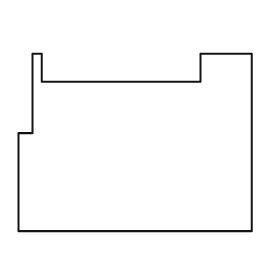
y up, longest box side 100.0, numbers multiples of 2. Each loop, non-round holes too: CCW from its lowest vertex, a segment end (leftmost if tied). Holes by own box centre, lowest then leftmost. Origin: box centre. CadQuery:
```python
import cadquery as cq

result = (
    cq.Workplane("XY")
    .moveTo(-50.0, -38.0)
    .lineTo(50.0, -38.0)
    .lineTo(50.0, 38.0)
    .lineTo(28.0, 38.0)
    .lineTo(28.0, 26.0)
    .lineTo(-40.0, 26.0)
    .lineTo(-40.0, 38.0)
    .lineTo(-44.0, 38.0)
    .lineTo(-44.0, 4.0)
    .lineTo(-50.0, 4.0)
    .close()
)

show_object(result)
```